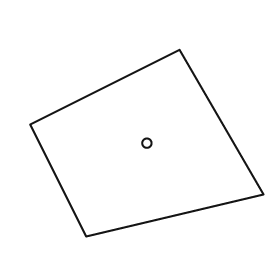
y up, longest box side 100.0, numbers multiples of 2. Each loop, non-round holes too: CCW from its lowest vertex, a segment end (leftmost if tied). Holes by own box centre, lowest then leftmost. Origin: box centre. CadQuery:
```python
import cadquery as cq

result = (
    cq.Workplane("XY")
    .moveTo(-26.0, -40.0)
    .lineTo(50.0, -22.0)
    .lineTo(14.0, 40.0)
    .lineTo(-50.0, 8.0)
    .close()
    .moveTo(0.0, 0.0)
    .circle(2.0)
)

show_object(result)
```